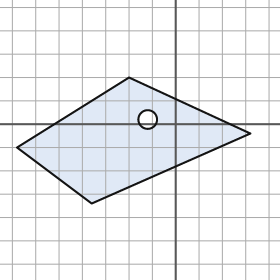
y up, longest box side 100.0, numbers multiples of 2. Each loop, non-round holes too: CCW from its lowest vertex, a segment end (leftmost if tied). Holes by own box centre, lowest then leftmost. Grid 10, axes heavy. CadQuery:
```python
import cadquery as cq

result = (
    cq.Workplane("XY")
    .moveTo(-36.0, -34.0)
    .lineTo(32.0, -4.0)
    .lineTo(-20.0, 20.0)
    .lineTo(-68.0, -10.0)
    .close()
    .moveTo(-12.0, 2.0)
    .circle(4.0)
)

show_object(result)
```